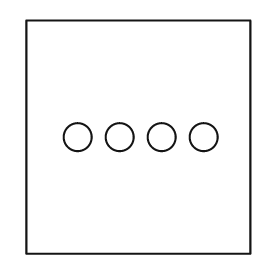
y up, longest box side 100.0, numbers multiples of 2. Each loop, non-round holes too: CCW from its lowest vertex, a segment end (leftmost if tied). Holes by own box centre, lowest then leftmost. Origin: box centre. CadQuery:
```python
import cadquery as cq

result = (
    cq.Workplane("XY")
    .moveTo(-48.0, -50.0)
    .lineTo(48.0, -50.0)
    .lineTo(48.0, 50.0)
    .lineTo(-48.0, 50.0)
    .close()
    .moveTo(-26.0, 0.0)
    .circle(6.0)
    .moveTo(-8.0, 0.0)
    .circle(6.0)
    .moveTo(10.0, 0.0)
    .circle(6.0)
    .moveTo(28.0, 0.0)
    .circle(6.0)
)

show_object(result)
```